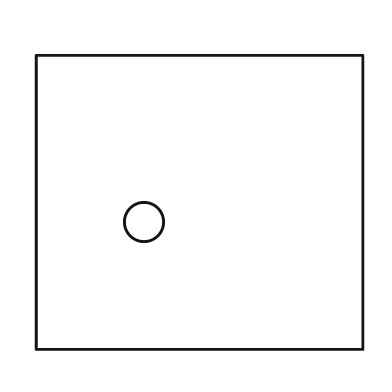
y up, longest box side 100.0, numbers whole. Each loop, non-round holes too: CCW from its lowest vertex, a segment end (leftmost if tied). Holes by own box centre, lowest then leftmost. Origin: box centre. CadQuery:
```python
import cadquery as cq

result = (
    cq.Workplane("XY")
    .moveTo(-50.0, -45.0)
    .lineTo(50.0, -45.0)
    .lineTo(50.0, 45.0)
    .lineTo(-50.0, 45.0)
    .close()
    .moveTo(-17.0, -6.0)
    .circle(6.0)
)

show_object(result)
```